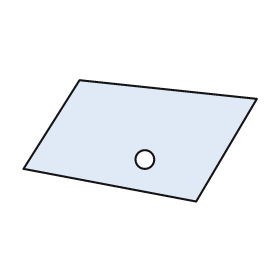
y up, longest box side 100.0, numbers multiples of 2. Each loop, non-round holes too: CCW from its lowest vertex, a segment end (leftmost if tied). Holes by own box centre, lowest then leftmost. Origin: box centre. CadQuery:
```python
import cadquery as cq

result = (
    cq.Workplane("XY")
    .moveTo(24.0, -26.0)
    .lineTo(50.0, 18.0)
    .lineTo(-26.0, 26.0)
    .lineTo(-50.0, -12.0)
    .close()
    .moveTo(2.0, -8.0)
    .circle(4.0)
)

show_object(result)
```